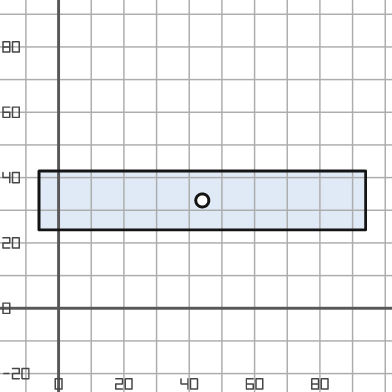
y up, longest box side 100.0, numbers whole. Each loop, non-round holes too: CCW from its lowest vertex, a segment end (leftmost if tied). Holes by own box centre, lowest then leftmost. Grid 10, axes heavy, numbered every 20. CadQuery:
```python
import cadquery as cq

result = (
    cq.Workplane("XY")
    .moveTo(-6.0, 24.0)
    .lineTo(94.0, 24.0)
    .lineTo(94.0, 42.0)
    .lineTo(-6.0, 42.0)
    .close()
    .moveTo(44.0, 33.0)
    .circle(2.0)
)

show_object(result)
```